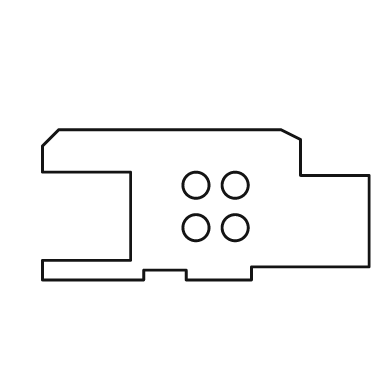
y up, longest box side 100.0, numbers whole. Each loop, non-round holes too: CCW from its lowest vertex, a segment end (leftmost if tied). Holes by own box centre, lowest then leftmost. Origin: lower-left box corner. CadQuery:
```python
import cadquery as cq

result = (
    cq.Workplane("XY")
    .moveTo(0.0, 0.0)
    .lineTo(31.0, 0.0)
    .lineTo(31.0, 3.0)
    .lineTo(44.0, 3.0)
    .lineTo(44.0, 0.0)
    .lineTo(64.0, 0.0)
    .lineTo(64.0, 4.0)
    .lineTo(100.0, 4.0)
    .lineTo(100.0, 32.0)
    .lineTo(79.0, 32.0)
    .lineTo(79.0, 43.0)
    .lineTo(73.0, 46.0)
    .lineTo(5.0, 46.0)
    .lineTo(0.0, 41.0)
    .lineTo(0.0, 33.0)
    .lineTo(27.0, 33.0)
    .lineTo(27.0, 6.0)
    .lineTo(0.0, 6.0)
    .close()
    .moveTo(47.0, 16.0)
    .circle(4.0)
    .moveTo(59.0, 16.0)
    .circle(4.0)
    .moveTo(47.0, 29.0)
    .circle(4.0)
    .moveTo(59.0, 29.0)
    .circle(4.0)
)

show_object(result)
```